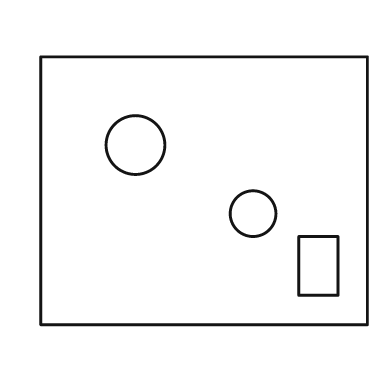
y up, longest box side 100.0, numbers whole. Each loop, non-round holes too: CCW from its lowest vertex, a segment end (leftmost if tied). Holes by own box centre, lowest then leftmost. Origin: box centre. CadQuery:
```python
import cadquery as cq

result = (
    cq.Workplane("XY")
    .moveTo(-50.0, -41.0)
    .lineTo(50.0, -41.0)
    .lineTo(50.0, 41.0)
    .lineTo(-50.0, 41.0)
    .close()
    .moveTo(29.0, -32.0)
    .lineTo(41.0, -32.0)
    .lineTo(41.0, -14.0)
    .lineTo(29.0, -14.0)
    .close()
    .moveTo(15.0, -7.0)
    .circle(7.0)
    .moveTo(-21.0, 14.0)
    .circle(9.0)
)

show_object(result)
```